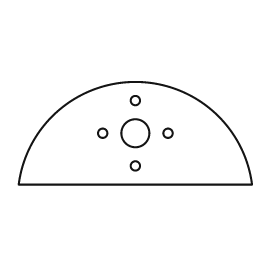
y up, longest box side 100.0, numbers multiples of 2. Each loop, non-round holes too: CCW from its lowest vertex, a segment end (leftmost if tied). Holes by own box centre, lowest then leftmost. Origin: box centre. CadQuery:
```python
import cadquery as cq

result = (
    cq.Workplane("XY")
    .moveTo(-50.0, -22.0)
    .lineTo(50.0, -22.0)
    .threePointArc((0.0, 22.0), (-50.0, -22.0))
    .close()
    .moveTo(0.0, -14.0)
    .circle(2.0)
    .moveTo(-14.0, 0.0)
    .circle(2.0)
    .moveTo(0.0, 0.0)
    .circle(6.0)
    .moveTo(14.0, 0.0)
    .circle(2.0)
    .moveTo(0.0, 14.0)
    .circle(2.0)
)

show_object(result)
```